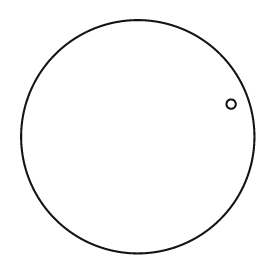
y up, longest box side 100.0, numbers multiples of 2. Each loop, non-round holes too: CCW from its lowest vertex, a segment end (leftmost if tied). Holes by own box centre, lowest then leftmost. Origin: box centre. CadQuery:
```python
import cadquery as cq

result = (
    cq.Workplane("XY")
    .moveTo(0.0, 0.0)
    .circle(50.0)
    .moveTo(40.0, 14.0)
    .circle(2.0)
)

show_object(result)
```